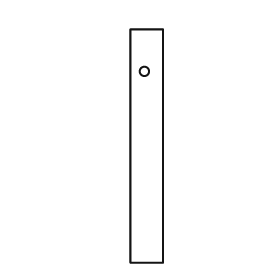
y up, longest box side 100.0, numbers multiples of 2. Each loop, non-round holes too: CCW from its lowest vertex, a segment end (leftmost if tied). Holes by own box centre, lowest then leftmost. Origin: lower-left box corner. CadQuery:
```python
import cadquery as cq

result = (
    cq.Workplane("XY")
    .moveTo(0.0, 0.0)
    .lineTo(14.0, 0.0)
    .lineTo(14.0, 100.0)
    .lineTo(0.0, 100.0)
    .close()
    .moveTo(6.0, 82.0)
    .circle(2.0)
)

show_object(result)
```